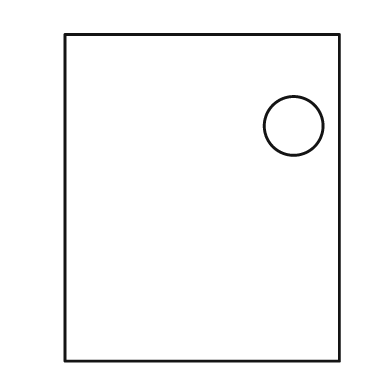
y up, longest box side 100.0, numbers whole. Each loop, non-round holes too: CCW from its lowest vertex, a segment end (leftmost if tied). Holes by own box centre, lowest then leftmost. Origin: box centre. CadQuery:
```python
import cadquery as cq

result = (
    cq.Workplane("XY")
    .moveTo(-42.0, -50.0)
    .lineTo(42.0, -50.0)
    .lineTo(42.0, 50.0)
    .lineTo(-42.0, 50.0)
    .close()
    .moveTo(28.0, 22.0)
    .circle(9.0)
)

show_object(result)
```